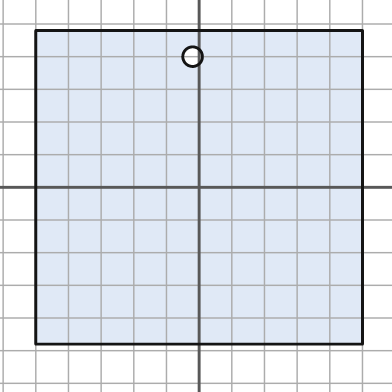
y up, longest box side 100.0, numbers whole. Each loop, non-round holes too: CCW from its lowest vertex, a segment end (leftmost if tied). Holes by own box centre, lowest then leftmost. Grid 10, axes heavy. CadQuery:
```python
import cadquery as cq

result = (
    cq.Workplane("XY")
    .moveTo(-50.0, -48.0)
    .lineTo(50.0, -48.0)
    .lineTo(50.0, 48.0)
    .lineTo(-50.0, 48.0)
    .close()
    .moveTo(-2.0, 40.0)
    .circle(3.0)
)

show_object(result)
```